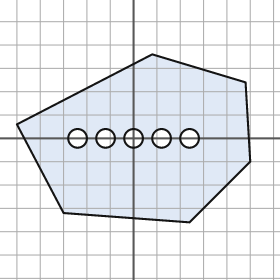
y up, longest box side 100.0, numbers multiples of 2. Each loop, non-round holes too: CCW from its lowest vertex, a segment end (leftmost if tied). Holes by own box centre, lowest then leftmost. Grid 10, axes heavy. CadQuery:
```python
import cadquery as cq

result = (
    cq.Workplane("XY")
    .moveTo(24.0, -36.0)
    .lineTo(50.0, -10.0)
    .lineTo(48.0, 24.0)
    .lineTo(8.0, 36.0)
    .lineTo(-50.0, 6.0)
    .lineTo(-30.0, -32.0)
    .close()
    .moveTo(-24.0, 0.0)
    .circle(4.0)
    .moveTo(-12.0, 0.0)
    .circle(4.0)
    .moveTo(0.0, 0.0)
    .circle(4.0)
    .moveTo(12.0, 0.0)
    .circle(4.0)
    .moveTo(24.0, 0.0)
    .circle(4.0)
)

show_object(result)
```